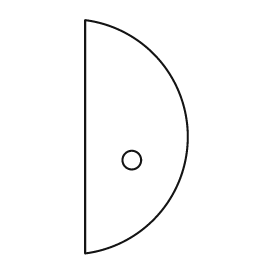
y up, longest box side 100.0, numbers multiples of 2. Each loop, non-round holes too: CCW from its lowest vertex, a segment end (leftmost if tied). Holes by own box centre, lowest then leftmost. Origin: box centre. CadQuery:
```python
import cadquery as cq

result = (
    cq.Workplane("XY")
    .moveTo(-22.0, -50.0)
    .threePointArc((22.0, 0.0), (-22.0, 50.0))
    .close()
    .moveTo(-2.0, -10.0)
    .circle(4.0)
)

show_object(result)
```